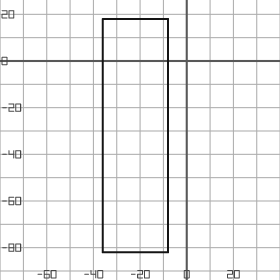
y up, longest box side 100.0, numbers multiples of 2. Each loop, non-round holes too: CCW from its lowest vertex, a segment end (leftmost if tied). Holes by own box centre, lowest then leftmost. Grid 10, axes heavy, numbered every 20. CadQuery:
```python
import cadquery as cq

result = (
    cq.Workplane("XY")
    .moveTo(-36.0, -82.0)
    .lineTo(-8.0, -82.0)
    .lineTo(-8.0, 18.0)
    .lineTo(-36.0, 18.0)
    .close()
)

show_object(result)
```